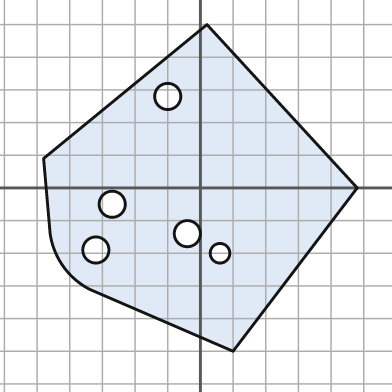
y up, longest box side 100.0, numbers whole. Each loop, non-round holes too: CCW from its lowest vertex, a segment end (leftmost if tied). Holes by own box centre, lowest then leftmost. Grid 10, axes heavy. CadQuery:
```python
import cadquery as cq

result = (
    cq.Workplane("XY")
    .moveTo(10.0, -50.0)
    .lineTo(48.0, 0.0)
    .lineTo(2.0, 50.0)
    .lineTo(-48.0, 9.0)
    .lineTo(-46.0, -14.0)
    .threePointArc((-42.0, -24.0), (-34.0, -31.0))
    .close()
    .moveTo(6.0, -20.0)
    .circle(3.0)
    .moveTo(-32.0, -19.0)
    .circle(4.0)
    .moveTo(-4.0, -14.0)
    .circle(4.0)
    .moveTo(-27.0, -5.0)
    .circle(4.0)
    .moveTo(-10.0, 28.0)
    .circle(4.0)
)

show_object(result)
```